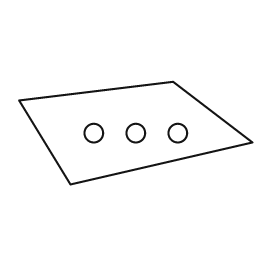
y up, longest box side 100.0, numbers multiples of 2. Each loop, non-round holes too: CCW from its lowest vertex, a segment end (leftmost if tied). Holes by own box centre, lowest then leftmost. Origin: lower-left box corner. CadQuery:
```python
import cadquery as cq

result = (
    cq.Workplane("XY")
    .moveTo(22.0, 0.0)
    .lineTo(100.0, 18.0)
    .lineTo(66.0, 44.0)
    .lineTo(0.0, 36.0)
    .close()
    .moveTo(32.0, 22.0)
    .circle(4.0)
    .moveTo(50.0, 22.0)
    .circle(4.0)
    .moveTo(68.0, 22.0)
    .circle(4.0)
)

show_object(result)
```